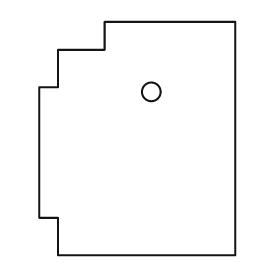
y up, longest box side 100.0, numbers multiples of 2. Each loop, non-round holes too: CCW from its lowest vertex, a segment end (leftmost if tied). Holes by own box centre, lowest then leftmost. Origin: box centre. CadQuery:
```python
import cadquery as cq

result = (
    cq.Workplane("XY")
    .moveTo(-34.0, -50.0)
    .lineTo(42.0, -50.0)
    .lineTo(42.0, 50.0)
    .lineTo(-14.0, 50.0)
    .lineTo(-14.0, 38.0)
    .lineTo(-34.0, 38.0)
    .lineTo(-34.0, 22.0)
    .lineTo(-42.0, 22.0)
    .lineTo(-42.0, -34.0)
    .lineTo(-34.0, -34.0)
    .close()
    .moveTo(6.0, 20.0)
    .circle(4.0)
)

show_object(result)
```